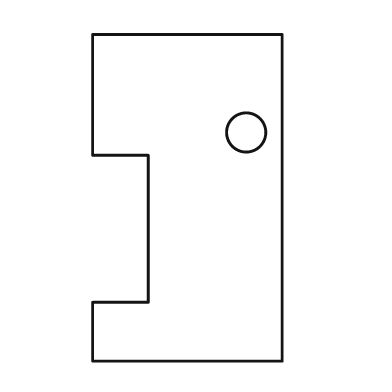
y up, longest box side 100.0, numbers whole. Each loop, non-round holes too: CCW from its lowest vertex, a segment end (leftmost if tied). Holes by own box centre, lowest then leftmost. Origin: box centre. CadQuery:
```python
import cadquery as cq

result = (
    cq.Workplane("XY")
    .moveTo(-29.0, -50.0)
    .lineTo(29.0, -50.0)
    .lineTo(29.0, 50.0)
    .lineTo(-29.0, 50.0)
    .lineTo(-29.0, 13.0)
    .lineTo(-12.0, 13.0)
    .lineTo(-12.0, -32.0)
    .lineTo(-29.0, -32.0)
    .close()
    .moveTo(18.0, 20.0)
    .circle(6.0)
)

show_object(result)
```